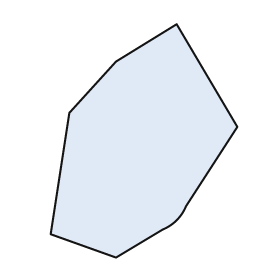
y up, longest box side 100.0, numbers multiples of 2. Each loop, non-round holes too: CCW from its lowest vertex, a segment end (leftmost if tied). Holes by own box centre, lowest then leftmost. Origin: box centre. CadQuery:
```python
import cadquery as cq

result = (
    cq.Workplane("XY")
    .moveTo(-12.0, -50.0)
    .lineTo(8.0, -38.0)
    .threePointArc((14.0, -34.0), (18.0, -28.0))
    .lineTo(40.0, 6.0)
    .lineTo(14.0, 50.0)
    .lineTo(-12.0, 34.0)
    .lineTo(-32.0, 12.0)
    .lineTo(-40.0, -40.0)
    .close()
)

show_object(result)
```